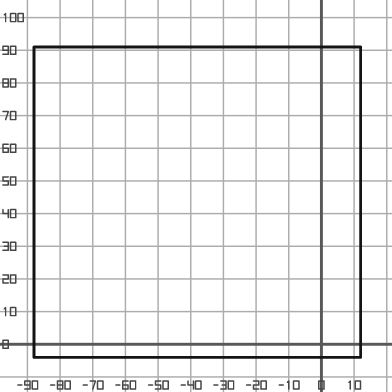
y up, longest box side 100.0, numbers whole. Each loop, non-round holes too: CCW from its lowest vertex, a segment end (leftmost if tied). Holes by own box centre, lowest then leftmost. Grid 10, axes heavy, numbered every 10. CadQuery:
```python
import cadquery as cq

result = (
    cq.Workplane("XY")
    .moveTo(-88.0, -4.0)
    .lineTo(12.0, -4.0)
    .lineTo(12.0, 91.0)
    .lineTo(-88.0, 91.0)
    .close()
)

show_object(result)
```